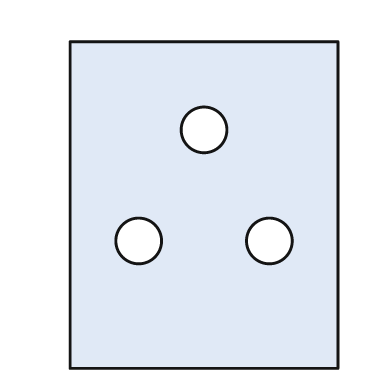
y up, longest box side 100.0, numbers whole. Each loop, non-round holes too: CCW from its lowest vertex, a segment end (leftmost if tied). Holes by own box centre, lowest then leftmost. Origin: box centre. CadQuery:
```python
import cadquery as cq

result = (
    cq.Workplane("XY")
    .moveTo(-41.0, -50.0)
    .lineTo(41.0, -50.0)
    .lineTo(41.0, 50.0)
    .lineTo(-41.0, 50.0)
    .close()
    .moveTo(-20.0, -11.0)
    .circle(7.0)
    .moveTo(20.0, -11.0)
    .circle(7.0)
    .moveTo(0.0, 23.0)
    .circle(7.0)
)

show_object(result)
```